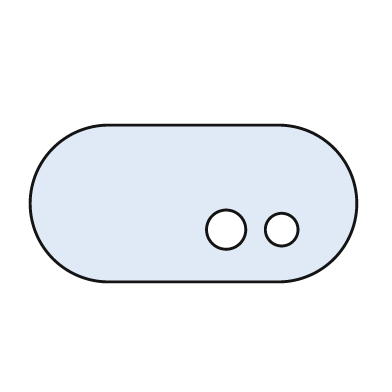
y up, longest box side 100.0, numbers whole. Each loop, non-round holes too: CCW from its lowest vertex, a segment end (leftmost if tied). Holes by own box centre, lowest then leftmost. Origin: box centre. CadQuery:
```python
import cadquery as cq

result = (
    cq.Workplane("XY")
    .moveTo(-26.0, -24.0)
    .lineTo(26.0, -24.0)
    .threePointArc((50.0, 0.0), (26.0, 24.0))
    .lineTo(-26.0, 24.0)
    .threePointArc((-50.0, 0.0), (-26.0, -24.0))
    .close()
    .moveTo(10.0, -8.0)
    .circle(6.0)
    .moveTo(27.0, -8.0)
    .circle(5.0)
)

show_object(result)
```